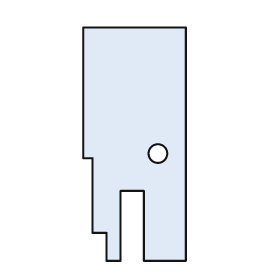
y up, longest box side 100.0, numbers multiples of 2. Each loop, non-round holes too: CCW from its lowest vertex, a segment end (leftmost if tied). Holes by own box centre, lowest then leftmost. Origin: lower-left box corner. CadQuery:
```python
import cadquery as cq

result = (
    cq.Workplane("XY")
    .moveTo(10.0, 0.0)
    .lineTo(16.0, 0.0)
    .lineTo(16.0, 30.0)
    .lineTo(26.0, 30.0)
    .lineTo(26.0, 0.0)
    .lineTo(44.0, 0.0)
    .lineTo(44.0, 100.0)
    .lineTo(0.0, 100.0)
    .lineTo(0.0, 44.0)
    .lineTo(4.0, 44.0)
    .lineTo(4.0, 12.0)
    .lineTo(10.0, 12.0)
    .close()
    .moveTo(32.0, 46.0)
    .circle(4.0)
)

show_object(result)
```